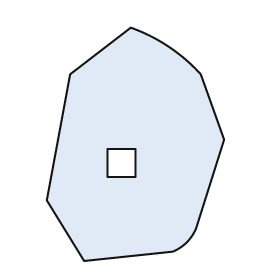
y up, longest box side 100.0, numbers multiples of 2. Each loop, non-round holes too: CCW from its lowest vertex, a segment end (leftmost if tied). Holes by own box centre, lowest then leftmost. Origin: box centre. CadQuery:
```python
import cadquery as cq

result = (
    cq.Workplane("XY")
    .moveTo(-22.0, -50.0)
    .lineTo(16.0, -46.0)
    .threePointArc((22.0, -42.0), (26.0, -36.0))
    .lineTo(38.0, 2.0)
    .lineTo(28.0, 30.0)
    .threePointArc((14.0, 42.0), (-2.0, 50.0))
    .lineTo(-28.0, 30.0)
    .lineTo(-38.0, -24.0)
    .close()
    .moveTo(-12.0, -14.0)
    .lineTo(0.0, -14.0)
    .lineTo(0.0, -2.0)
    .lineTo(-12.0, -2.0)
    .close()
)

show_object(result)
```